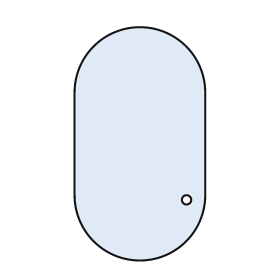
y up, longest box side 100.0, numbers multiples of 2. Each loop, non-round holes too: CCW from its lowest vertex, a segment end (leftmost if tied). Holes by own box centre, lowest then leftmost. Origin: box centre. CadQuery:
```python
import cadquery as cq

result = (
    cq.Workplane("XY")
    .moveTo(-28.0, -22.0)
    .threePointArc((0.0, -50.0), (28.0, -22.0))
    .lineTo(28.0, 22.0)
    .threePointArc((0.0, 50.0), (-28.0, 22.0))
    .close()
    .moveTo(20.0, -24.0)
    .circle(2.0)
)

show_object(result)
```